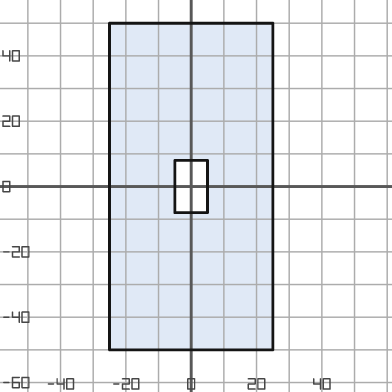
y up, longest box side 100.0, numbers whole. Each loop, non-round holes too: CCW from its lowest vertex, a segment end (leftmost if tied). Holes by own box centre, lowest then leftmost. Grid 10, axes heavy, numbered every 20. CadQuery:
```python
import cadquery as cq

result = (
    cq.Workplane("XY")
    .moveTo(-25.0, -50.0)
    .lineTo(25.0, -50.0)
    .lineTo(25.0, 50.0)
    .lineTo(-25.0, 50.0)
    .close()
    .moveTo(-5.0, -8.0)
    .lineTo(5.0, -8.0)
    .lineTo(5.0, 8.0)
    .lineTo(-5.0, 8.0)
    .close()
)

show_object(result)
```